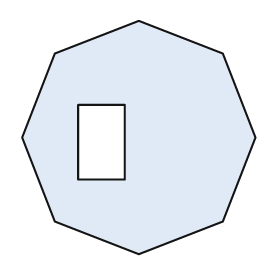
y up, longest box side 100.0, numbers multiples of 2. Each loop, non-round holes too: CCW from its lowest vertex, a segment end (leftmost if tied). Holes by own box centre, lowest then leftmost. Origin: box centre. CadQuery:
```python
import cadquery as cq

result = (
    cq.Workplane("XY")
    .moveTo(0.0, -50.0)
    .lineTo(36.0, -36.0)
    .lineTo(50.0, 0.0)
    .lineTo(36.0, 36.0)
    .lineTo(0.0, 50.0)
    .lineTo(-36.0, 36.0)
    .lineTo(-50.0, 0.0)
    .lineTo(-36.0, -36.0)
    .close()
    .moveTo(-26.0, -18.0)
    .lineTo(-6.0, -18.0)
    .lineTo(-6.0, 14.0)
    .lineTo(-26.0, 14.0)
    .close()
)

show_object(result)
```